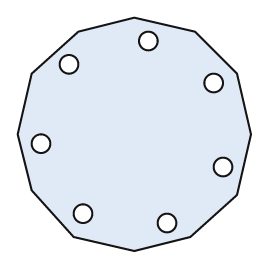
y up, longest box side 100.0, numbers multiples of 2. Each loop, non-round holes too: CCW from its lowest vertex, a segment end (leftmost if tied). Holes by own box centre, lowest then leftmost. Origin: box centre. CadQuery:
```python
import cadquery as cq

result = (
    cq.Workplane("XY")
    .moveTo(0.0, -50.0)
    .lineTo(24.0, -44.0)
    .lineTo(44.0, -26.0)
    .lineTo(50.0, 0.0)
    .lineTo(44.0, 26.0)
    .lineTo(26.0, 44.0)
    .lineTo(0.0, 50.0)
    .lineTo(-24.0, 44.0)
    .lineTo(-44.0, 26.0)
    .lineTo(-50.0, 0.0)
    .lineTo(-44.0, -24.0)
    .lineTo(-26.0, -44.0)
    .close()
    .moveTo(14.0, -38.0)
    .circle(4.0)
    .moveTo(-22.0, -34.0)
    .circle(4.0)
    .moveTo(38.0, -14.0)
    .circle(4.0)
    .moveTo(-40.0, -4.0)
    .circle(4.0)
    .moveTo(34.0, 22.0)
    .circle(4.0)
    .moveTo(-28.0, 30.0)
    .circle(4.0)
    .moveTo(6.0, 40.0)
    .circle(4.0)
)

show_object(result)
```